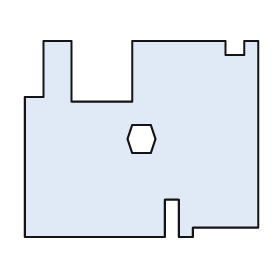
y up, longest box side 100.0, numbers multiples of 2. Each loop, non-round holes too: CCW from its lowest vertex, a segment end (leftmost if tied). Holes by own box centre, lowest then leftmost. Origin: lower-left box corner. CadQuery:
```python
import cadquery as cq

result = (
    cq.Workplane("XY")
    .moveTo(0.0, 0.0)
    .lineTo(60.0, 0.0)
    .lineTo(60.0, 16.0)
    .lineTo(66.0, 16.0)
    .lineTo(66.0, 0.0)
    .lineTo(72.0, 0.0)
    .lineTo(72.0, 4.0)
    .lineTo(100.0, 4.0)
    .lineTo(100.0, 84.0)
    .lineTo(94.0, 84.0)
    .lineTo(94.0, 78.0)
    .lineTo(86.0, 78.0)
    .lineTo(86.0, 84.0)
    .lineTo(46.0, 84.0)
    .lineTo(46.0, 58.0)
    .lineTo(20.0, 58.0)
    .lineTo(20.0, 84.0)
    .lineTo(8.0, 84.0)
    .lineTo(8.0, 60.0)
    .lineTo(0.0, 60.0)
    .close()
    .moveTo(46.0, 36.0)
    .lineTo(54.0, 36.0)
    .lineTo(56.0, 42.0)
    .lineTo(54.0, 48.0)
    .lineTo(46.0, 48.0)
    .lineTo(44.0, 42.0)
    .close()
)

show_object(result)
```